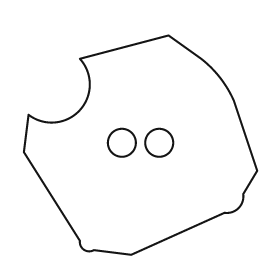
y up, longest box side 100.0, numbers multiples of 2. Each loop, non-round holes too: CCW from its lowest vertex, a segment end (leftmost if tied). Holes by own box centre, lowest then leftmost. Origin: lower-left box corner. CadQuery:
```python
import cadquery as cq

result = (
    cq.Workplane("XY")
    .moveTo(46.0, 0.0)
    .lineTo(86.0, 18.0)
    .threePointArc((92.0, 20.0), (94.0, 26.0))
    .lineTo(100.0, 36.0)
    .lineTo(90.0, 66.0)
    .threePointArc((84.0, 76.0), (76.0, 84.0))
    .lineTo(62.0, 94.0)
    .lineTo(24.0, 84.0)
    .threePointArc((24.0, 62.0), (2.0, 60.0))
    .lineTo(0.0, 44.0)
    .lineTo(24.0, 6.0)
    .threePointArc((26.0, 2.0), (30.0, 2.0))
    .close()
    .moveTo(42.0, 48.0)
    .circle(6.0)
    .moveTo(58.0, 48.0)
    .circle(6.0)
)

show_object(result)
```